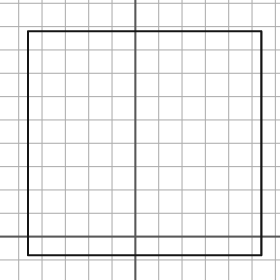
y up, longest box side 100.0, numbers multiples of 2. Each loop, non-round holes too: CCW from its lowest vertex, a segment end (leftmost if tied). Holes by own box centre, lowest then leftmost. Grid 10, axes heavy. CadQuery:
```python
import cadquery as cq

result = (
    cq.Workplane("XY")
    .moveTo(-46.0, -8.0)
    .lineTo(54.0, -8.0)
    .lineTo(54.0, 88.0)
    .lineTo(-46.0, 88.0)
    .close()
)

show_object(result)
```